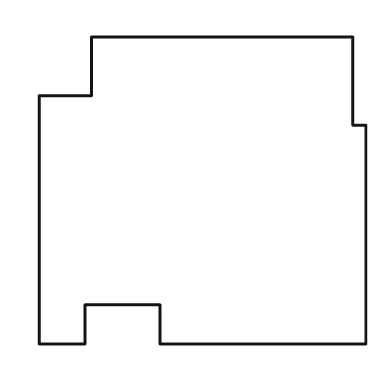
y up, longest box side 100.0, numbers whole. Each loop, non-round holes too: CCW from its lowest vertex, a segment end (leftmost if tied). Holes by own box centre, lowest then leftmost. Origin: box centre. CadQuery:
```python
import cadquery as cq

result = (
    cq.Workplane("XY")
    .moveTo(-50.0, -47.0)
    .lineTo(-36.0, -47.0)
    .lineTo(-36.0, -35.0)
    .lineTo(-13.0, -35.0)
    .lineTo(-13.0, -47.0)
    .lineTo(50.0, -47.0)
    .lineTo(50.0, 20.0)
    .lineTo(46.0, 20.0)
    .lineTo(46.0, 47.0)
    .lineTo(-34.0, 47.0)
    .lineTo(-34.0, 29.0)
    .lineTo(-50.0, 29.0)
    .close()
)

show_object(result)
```